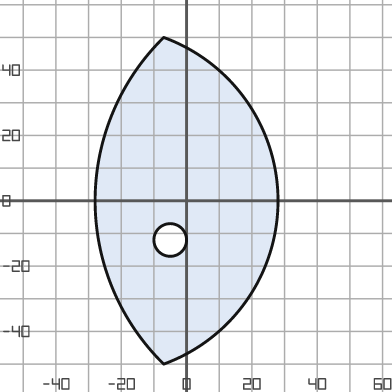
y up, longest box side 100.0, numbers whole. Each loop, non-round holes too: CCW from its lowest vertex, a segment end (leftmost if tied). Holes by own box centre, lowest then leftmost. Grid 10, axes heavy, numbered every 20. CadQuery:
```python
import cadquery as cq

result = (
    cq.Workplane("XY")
    .moveTo(-7.0, -50.0)
    .threePointArc((28.0, 0.0), (-7.0, 50.0))
    .threePointArc((-28.0, 0.0), (-7.0, -50.0))
    .close()
    .moveTo(-5.0, -12.0)
    .circle(5.0)
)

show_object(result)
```